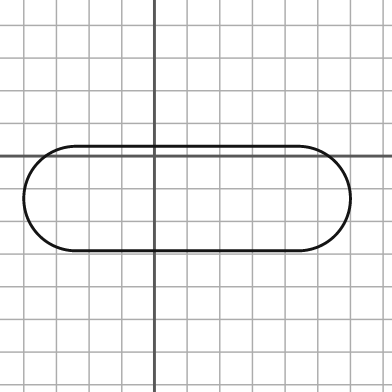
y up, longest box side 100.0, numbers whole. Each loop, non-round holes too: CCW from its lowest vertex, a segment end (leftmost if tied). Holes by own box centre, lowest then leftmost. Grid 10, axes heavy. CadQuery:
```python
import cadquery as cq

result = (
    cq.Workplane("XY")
    .moveTo(-24.0, -29.0)
    .lineTo(44.0, -29.0)
    .threePointArc((60.0, -13.0), (44.0, 3.0))
    .lineTo(-24.0, 3.0)
    .threePointArc((-40.0, -13.0), (-24.0, -29.0))
    .close()
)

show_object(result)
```